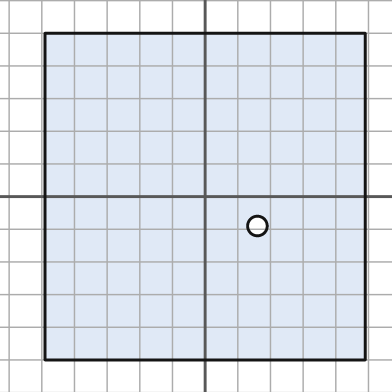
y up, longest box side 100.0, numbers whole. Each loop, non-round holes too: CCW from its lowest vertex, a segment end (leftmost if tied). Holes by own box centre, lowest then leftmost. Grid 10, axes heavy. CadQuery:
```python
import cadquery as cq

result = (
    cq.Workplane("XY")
    .moveTo(-49.0, -50.0)
    .lineTo(49.0, -50.0)
    .lineTo(49.0, 50.0)
    .lineTo(-49.0, 50.0)
    .close()
    .moveTo(16.0, -9.0)
    .circle(3.0)
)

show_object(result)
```